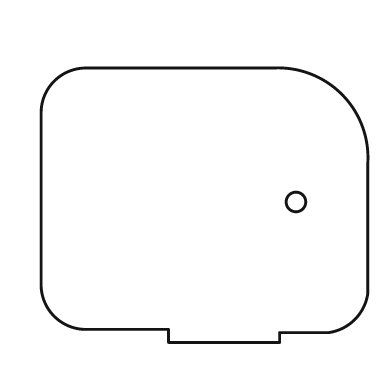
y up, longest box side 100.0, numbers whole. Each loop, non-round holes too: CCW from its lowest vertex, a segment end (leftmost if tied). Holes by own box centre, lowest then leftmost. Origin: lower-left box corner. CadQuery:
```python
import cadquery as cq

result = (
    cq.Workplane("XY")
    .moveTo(39.0, 0.0)
    .lineTo(73.0, 0.0)
    .lineTo(73.0, 3.0)
    .lineTo(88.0, 3.0)
    .threePointArc((96.0, 7.0), (100.0, 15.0))
    .lineTo(100.0, 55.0)
    .threePointArc((92.0, 76.0), (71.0, 84.0))
    .lineTo(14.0, 84.0)
    .threePointArc((4.0, 80.0), (0.0, 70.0))
    .lineTo(0.0, 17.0)
    .threePointArc((4.0, 8.0), (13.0, 4.0))
    .lineTo(39.0, 4.0)
    .close()
    .moveTo(78.0, 43.0)
    .circle(3.0)
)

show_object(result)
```